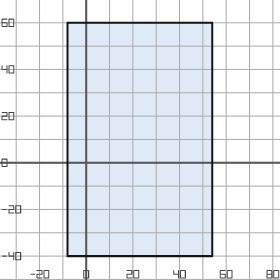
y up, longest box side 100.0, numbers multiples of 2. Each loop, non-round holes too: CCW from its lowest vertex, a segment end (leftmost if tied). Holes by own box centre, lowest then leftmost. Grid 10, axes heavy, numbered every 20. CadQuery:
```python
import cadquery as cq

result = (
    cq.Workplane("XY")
    .moveTo(-8.0, -40.0)
    .lineTo(54.0, -40.0)
    .lineTo(54.0, 60.0)
    .lineTo(-8.0, 60.0)
    .close()
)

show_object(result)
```